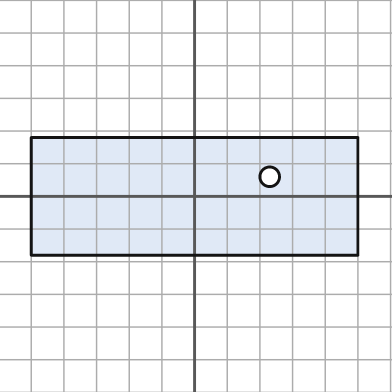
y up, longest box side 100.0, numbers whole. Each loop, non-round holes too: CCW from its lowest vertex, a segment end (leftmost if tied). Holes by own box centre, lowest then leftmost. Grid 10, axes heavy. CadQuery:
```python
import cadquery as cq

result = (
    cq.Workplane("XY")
    .moveTo(-50.0, -18.0)
    .lineTo(50.0, -18.0)
    .lineTo(50.0, 18.0)
    .lineTo(-50.0, 18.0)
    .close()
    .moveTo(23.0, 6.0)
    .circle(3.0)
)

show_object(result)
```